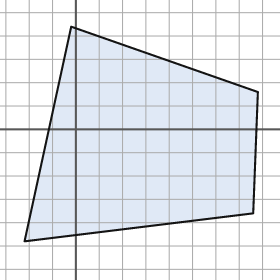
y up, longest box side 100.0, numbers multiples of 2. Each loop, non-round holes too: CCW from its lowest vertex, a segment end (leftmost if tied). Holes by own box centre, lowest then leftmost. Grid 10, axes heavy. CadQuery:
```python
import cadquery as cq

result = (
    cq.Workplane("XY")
    .moveTo(-22.0, -48.0)
    .lineTo(76.0, -36.0)
    .lineTo(78.0, 16.0)
    .lineTo(-2.0, 44.0)
    .close()
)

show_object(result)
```